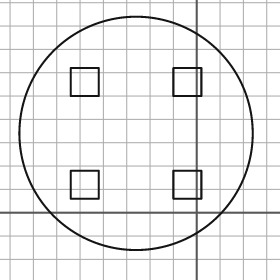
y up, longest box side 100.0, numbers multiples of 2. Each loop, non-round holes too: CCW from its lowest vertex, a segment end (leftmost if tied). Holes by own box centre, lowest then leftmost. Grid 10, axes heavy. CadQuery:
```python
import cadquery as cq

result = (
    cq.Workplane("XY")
    .moveTo(-26.0, 34.0)
    .circle(50.0)
    .moveTo(-54.0, 6.0)
    .lineTo(-42.0, 6.0)
    .lineTo(-42.0, 18.0)
    .lineTo(-54.0, 18.0)
    .close()
    .moveTo(-10.0, 6.0)
    .lineTo(2.0, 6.0)
    .lineTo(2.0, 18.0)
    .lineTo(-10.0, 18.0)
    .close()
    .moveTo(-54.0, 50.0)
    .lineTo(-42.0, 50.0)
    .lineTo(-42.0, 62.0)
    .lineTo(-54.0, 62.0)
    .close()
    .moveTo(-10.0, 50.0)
    .lineTo(2.0, 50.0)
    .lineTo(2.0, 62.0)
    .lineTo(-10.0, 62.0)
    .close()
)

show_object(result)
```